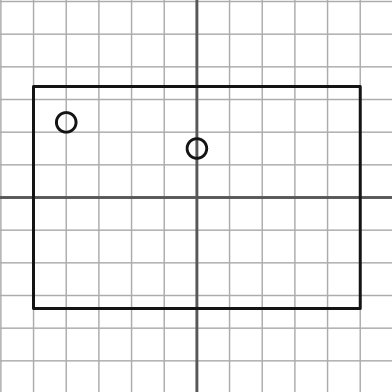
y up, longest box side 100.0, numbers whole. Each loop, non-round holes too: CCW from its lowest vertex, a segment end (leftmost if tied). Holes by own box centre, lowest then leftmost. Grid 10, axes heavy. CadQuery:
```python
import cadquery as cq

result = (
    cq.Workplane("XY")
    .moveTo(-50.0, -34.0)
    .lineTo(50.0, -34.0)
    .lineTo(50.0, 34.0)
    .lineTo(-50.0, 34.0)
    .close()
    .moveTo(0.0, 15.0)
    .circle(3.0)
    .moveTo(-40.0, 23.0)
    .circle(3.0)
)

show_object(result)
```